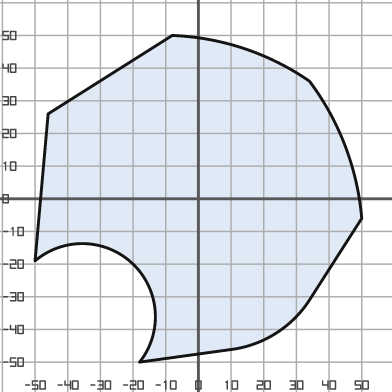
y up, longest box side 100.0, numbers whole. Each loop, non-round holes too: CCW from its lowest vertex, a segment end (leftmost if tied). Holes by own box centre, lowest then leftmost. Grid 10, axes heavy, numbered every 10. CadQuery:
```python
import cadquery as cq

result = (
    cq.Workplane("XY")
    .moveTo(-18.0, -50.0)
    .lineTo(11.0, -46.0)
    .threePointArc((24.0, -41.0), (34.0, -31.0))
    .lineTo(50.0, -6.0)
    .threePointArc((45.0, 16.0), (34.0, 36.0))
    .threePointArc((14.0, 46.0), (-8.0, 50.0))
    .lineTo(-46.0, 26.0)
    .lineTo(-50.0, -19.0)
    .threePointArc((-20.0, -20.0), (-18.0, -50.0))
    .close()
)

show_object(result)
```